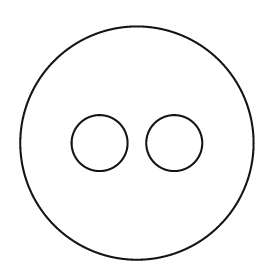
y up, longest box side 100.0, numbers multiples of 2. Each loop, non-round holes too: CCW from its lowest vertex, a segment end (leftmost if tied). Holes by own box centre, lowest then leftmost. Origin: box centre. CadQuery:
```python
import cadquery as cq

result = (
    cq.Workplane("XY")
    .moveTo(0.0, 0.0)
    .circle(50.0)
    .moveTo(-16.0, 0.0)
    .circle(12.0)
    .moveTo(16.0, 0.0)
    .circle(12.0)
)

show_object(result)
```